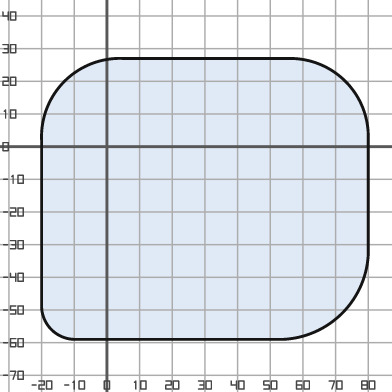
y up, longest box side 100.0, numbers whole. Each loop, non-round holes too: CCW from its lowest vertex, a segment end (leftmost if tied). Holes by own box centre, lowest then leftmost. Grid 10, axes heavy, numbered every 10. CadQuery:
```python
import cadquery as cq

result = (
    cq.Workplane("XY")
    .moveTo(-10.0, -59.0)
    .lineTo(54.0, -59.0)
    .threePointArc((72.0, -51.0), (80.0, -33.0))
    .lineTo(80.0, 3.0)
    .threePointArc((73.0, 20.0), (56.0, 27.0))
    .lineTo(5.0, 27.0)
    .threePointArc((-13.0, 20.0), (-20.0, 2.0))
    .lineTo(-20.0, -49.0)
    .threePointArc((-17.0, -56.0), (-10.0, -59.0))
    .close()
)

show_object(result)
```